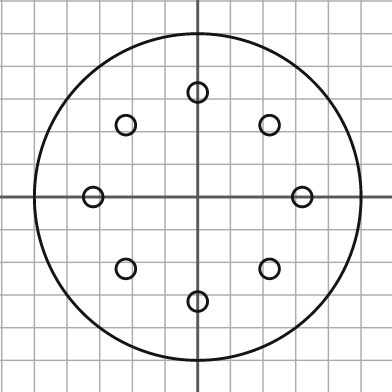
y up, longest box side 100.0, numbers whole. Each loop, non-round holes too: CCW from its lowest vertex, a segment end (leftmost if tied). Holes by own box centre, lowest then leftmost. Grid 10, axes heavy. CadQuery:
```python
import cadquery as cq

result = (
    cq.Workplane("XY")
    .moveTo(0.0, 0.0)
    .circle(50.0)
    .moveTo(0.0, -32.0)
    .circle(3.0)
    .moveTo(-22.0, -22.0)
    .circle(3.0)
    .moveTo(22.0, -22.0)
    .circle(3.0)
    .moveTo(-32.0, 0.0)
    .circle(3.0)
    .moveTo(32.0, 0.0)
    .circle(3.0)
    .moveTo(-22.0, 22.0)
    .circle(3.0)
    .moveTo(22.0, 22.0)
    .circle(3.0)
    .moveTo(0.0, 32.0)
    .circle(3.0)
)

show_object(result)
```